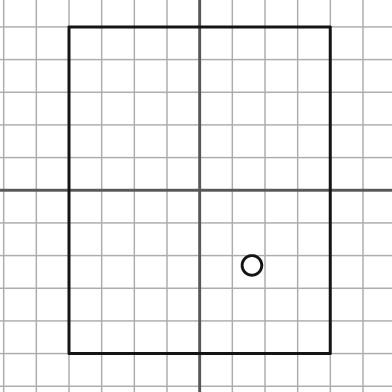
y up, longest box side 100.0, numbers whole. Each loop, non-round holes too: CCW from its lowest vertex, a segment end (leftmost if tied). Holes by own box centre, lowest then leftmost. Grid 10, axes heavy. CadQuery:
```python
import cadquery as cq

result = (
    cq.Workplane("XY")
    .moveTo(-40.0, -50.0)
    .lineTo(40.0, -50.0)
    .lineTo(40.0, 50.0)
    .lineTo(-40.0, 50.0)
    .close()
    .moveTo(16.0, -23.0)
    .circle(3.0)
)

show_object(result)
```